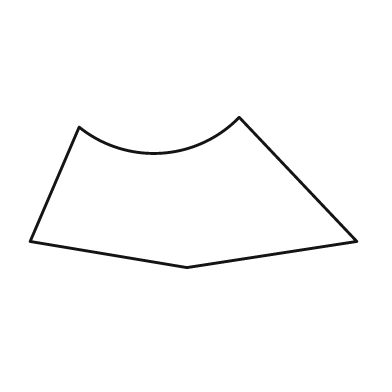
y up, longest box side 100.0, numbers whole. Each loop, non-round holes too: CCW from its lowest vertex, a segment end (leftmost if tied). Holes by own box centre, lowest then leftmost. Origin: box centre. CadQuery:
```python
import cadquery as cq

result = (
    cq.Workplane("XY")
    .moveTo(-2.0, -23.0)
    .lineTo(50.0, -15.0)
    .lineTo(14.0, 23.0)
    .threePointArc((-10.0, 12.0), (-35.0, 20.0))
    .lineTo(-50.0, -15.0)
    .close()
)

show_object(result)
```